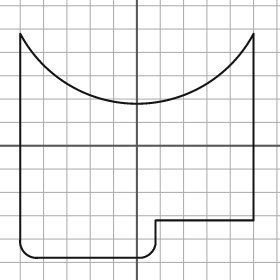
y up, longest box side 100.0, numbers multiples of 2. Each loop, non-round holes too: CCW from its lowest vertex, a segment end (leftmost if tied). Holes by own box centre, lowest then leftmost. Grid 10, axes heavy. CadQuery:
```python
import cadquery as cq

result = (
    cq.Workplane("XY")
    .moveTo(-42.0, -48.0)
    .lineTo(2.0, -48.0)
    .threePointArc((6.0, -46.0), (8.0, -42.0))
    .lineTo(8.0, -32.0)
    .lineTo(50.0, -32.0)
    .lineTo(50.0, 48.0)
    .threePointArc((0.0, 18.0), (-50.0, 48.0))
    .lineTo(-50.0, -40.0)
    .threePointArc((-48.0, -46.0), (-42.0, -48.0))
    .close()
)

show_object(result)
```